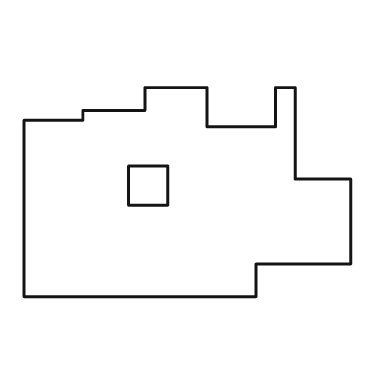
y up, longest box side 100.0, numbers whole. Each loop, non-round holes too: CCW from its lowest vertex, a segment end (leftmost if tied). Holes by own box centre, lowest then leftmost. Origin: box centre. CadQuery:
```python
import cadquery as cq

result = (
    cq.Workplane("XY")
    .moveTo(-50.0, -32.0)
    .lineTo(21.0, -32.0)
    .lineTo(21.0, -22.0)
    .lineTo(50.0, -22.0)
    .lineTo(50.0, 4.0)
    .lineTo(33.0, 4.0)
    .lineTo(33.0, 32.0)
    .lineTo(27.0, 32.0)
    .lineTo(27.0, 20.0)
    .lineTo(6.0, 20.0)
    .lineTo(6.0, 32.0)
    .lineTo(-13.0, 32.0)
    .lineTo(-13.0, 25.0)
    .lineTo(-32.0, 25.0)
    .lineTo(-32.0, 22.0)
    .lineTo(-50.0, 22.0)
    .close()
    .moveTo(-18.0, -4.0)
    .lineTo(-6.0, -4.0)
    .lineTo(-6.0, 8.0)
    .lineTo(-18.0, 8.0)
    .close()
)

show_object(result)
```